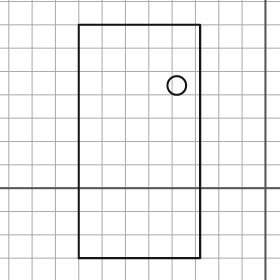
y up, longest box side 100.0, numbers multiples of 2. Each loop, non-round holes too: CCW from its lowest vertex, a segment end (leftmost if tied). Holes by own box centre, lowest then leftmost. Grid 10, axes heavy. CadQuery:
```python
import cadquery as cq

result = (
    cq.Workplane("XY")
    .moveTo(-80.0, -30.0)
    .lineTo(-28.0, -30.0)
    .lineTo(-28.0, 70.0)
    .lineTo(-80.0, 70.0)
    .close()
    .moveTo(-38.0, 44.0)
    .circle(4.0)
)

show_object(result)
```